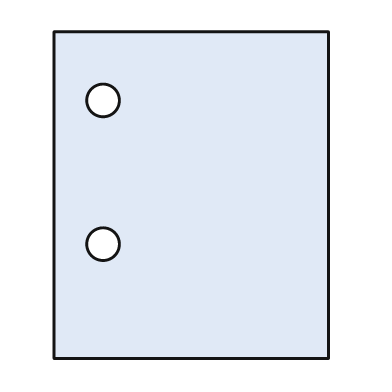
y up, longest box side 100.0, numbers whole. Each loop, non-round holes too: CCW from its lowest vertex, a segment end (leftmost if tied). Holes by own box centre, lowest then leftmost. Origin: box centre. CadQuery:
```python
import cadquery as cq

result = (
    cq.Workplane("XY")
    .moveTo(-42.0, -50.0)
    .lineTo(42.0, -50.0)
    .lineTo(42.0, 50.0)
    .lineTo(-42.0, 50.0)
    .close()
    .moveTo(-27.0, -15.0)
    .circle(5.0)
    .moveTo(-27.0, 29.0)
    .circle(5.0)
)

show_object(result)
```